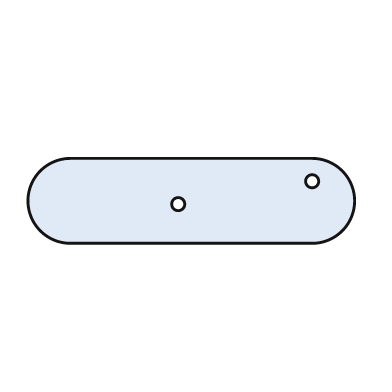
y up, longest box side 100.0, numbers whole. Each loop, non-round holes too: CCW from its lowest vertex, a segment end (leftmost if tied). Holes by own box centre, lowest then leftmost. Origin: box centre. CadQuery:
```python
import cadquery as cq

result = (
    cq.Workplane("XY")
    .moveTo(-37.0, -13.0)
    .lineTo(37.0, -13.0)
    .threePointArc((50.0, 0.0), (37.0, 13.0))
    .lineTo(-37.0, 13.0)
    .threePointArc((-50.0, 0.0), (-37.0, -13.0))
    .close()
    .moveTo(-4.0, -1.0)
    .circle(2.0)
    .moveTo(37.0, 6.0)
    .circle(2.0)
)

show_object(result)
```